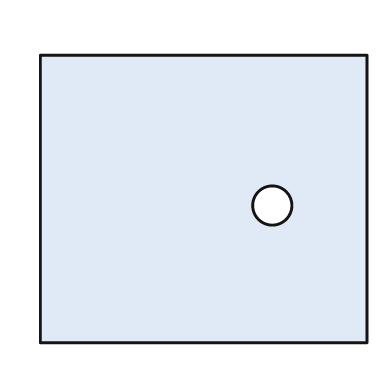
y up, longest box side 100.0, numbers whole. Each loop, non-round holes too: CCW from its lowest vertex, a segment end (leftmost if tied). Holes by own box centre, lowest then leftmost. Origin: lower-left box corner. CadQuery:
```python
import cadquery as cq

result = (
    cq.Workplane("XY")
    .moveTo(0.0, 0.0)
    .lineTo(100.0, 0.0)
    .lineTo(100.0, 88.0)
    .lineTo(0.0, 88.0)
    .close()
    .moveTo(71.0, 42.0)
    .circle(6.0)
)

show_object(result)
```